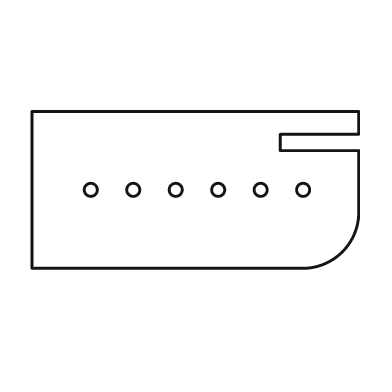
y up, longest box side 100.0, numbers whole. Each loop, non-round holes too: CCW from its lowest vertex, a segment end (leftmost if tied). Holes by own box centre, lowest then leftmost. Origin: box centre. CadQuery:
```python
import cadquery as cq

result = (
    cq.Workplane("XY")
    .moveTo(-50.0, -24.0)
    .lineTo(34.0, -24.0)
    .threePointArc((45.0, -19.0), (50.0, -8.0))
    .lineTo(50.0, 12.0)
    .lineTo(26.0, 12.0)
    .lineTo(26.0, 17.0)
    .lineTo(50.0, 17.0)
    .lineTo(50.0, 24.0)
    .lineTo(-50.0, 24.0)
    .close()
    .moveTo(-32.0, 0.0)
    .circle(2.0)
    .moveTo(-19.0, 0.0)
    .circle(2.0)
    .moveTo(-6.0, 0.0)
    .circle(2.0)
    .moveTo(7.0, 0.0)
    .circle(2.0)
    .moveTo(20.0, 0.0)
    .circle(2.0)
    .moveTo(33.0, 0.0)
    .circle(2.0)
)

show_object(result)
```